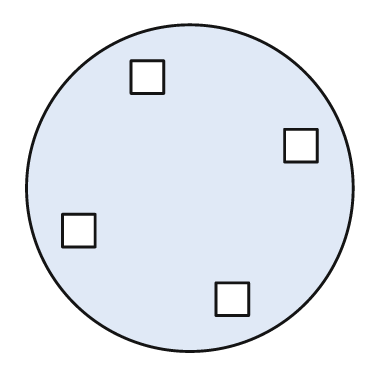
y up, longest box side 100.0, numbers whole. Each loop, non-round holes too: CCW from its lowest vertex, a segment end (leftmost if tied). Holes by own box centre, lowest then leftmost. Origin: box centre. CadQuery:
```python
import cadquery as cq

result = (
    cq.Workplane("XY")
    .moveTo(0.0, 0.0)
    .circle(50.0)
    .moveTo(8.0, -39.0)
    .lineTo(18.0, -39.0)
    .lineTo(18.0, -29.0)
    .lineTo(8.0, -29.0)
    .close()
    .moveTo(-39.0, -18.0)
    .lineTo(-29.0, -18.0)
    .lineTo(-29.0, -8.0)
    .lineTo(-39.0, -8.0)
    .close()
    .moveTo(29.0, 8.0)
    .lineTo(39.0, 8.0)
    .lineTo(39.0, 18.0)
    .lineTo(29.0, 18.0)
    .close()
    .moveTo(-18.0, 29.0)
    .lineTo(-8.0, 29.0)
    .lineTo(-8.0, 39.0)
    .lineTo(-18.0, 39.0)
    .close()
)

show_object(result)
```